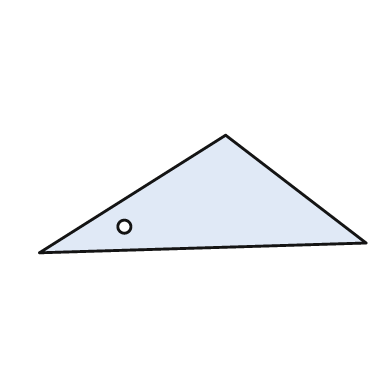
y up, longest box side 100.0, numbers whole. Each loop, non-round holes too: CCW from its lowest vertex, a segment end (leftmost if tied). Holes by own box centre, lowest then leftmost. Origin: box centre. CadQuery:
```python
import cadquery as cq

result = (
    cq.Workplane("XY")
    .moveTo(-50.0, -18.0)
    .lineTo(50.0, -15.0)
    .lineTo(7.0, 18.0)
    .close()
    .moveTo(-24.0, -10.0)
    .circle(2.0)
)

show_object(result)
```